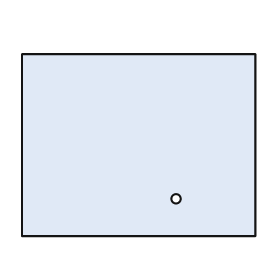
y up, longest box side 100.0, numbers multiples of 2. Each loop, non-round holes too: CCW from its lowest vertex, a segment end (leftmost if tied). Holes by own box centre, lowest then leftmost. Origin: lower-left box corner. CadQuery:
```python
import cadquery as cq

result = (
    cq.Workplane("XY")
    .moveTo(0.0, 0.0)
    .lineTo(100.0, 0.0)
    .lineTo(100.0, 78.0)
    .lineTo(0.0, 78.0)
    .close()
    .moveTo(66.0, 16.0)
    .circle(2.0)
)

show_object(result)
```